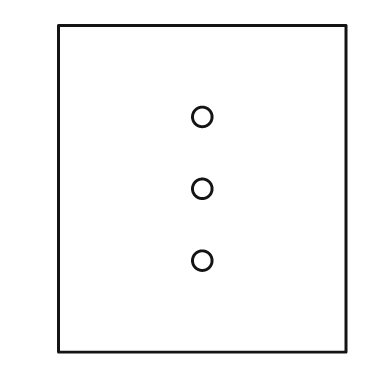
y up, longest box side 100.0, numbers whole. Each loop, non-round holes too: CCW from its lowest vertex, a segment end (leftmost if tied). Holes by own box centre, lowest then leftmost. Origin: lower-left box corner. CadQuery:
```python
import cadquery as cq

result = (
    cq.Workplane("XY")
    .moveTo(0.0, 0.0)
    .lineTo(88.0, 0.0)
    .lineTo(88.0, 100.0)
    .lineTo(0.0, 100.0)
    .close()
    .moveTo(44.0, 28.0)
    .circle(3.0)
    .moveTo(44.0, 50.0)
    .circle(3.0)
    .moveTo(44.0, 72.0)
    .circle(3.0)
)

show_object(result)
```